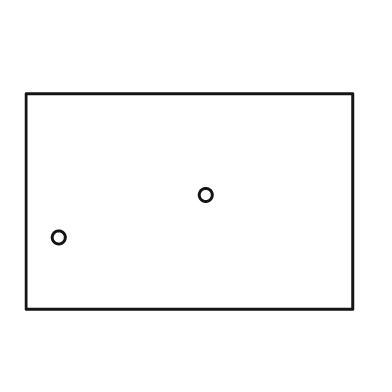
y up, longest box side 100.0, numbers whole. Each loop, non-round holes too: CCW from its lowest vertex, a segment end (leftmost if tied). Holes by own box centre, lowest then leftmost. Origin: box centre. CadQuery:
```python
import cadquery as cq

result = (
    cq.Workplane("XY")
    .moveTo(-50.0, -33.0)
    .lineTo(50.0, -33.0)
    .lineTo(50.0, 33.0)
    .lineTo(-50.0, 33.0)
    .close()
    .moveTo(-40.0, -11.0)
    .circle(2.0)
    .moveTo(5.0, 2.0)
    .circle(2.0)
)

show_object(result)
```